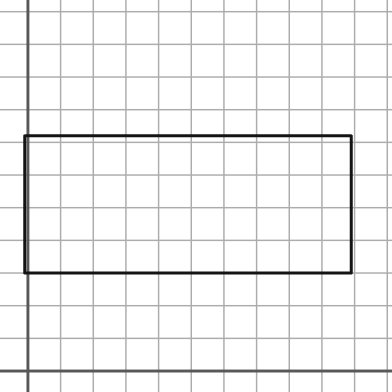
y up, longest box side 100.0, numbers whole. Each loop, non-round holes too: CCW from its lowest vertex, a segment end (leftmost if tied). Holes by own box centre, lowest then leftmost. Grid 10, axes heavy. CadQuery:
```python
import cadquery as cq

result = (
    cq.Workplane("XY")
    .moveTo(-1.0, 30.0)
    .lineTo(99.0, 30.0)
    .lineTo(99.0, 72.0)
    .lineTo(-1.0, 72.0)
    .close()
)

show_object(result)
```